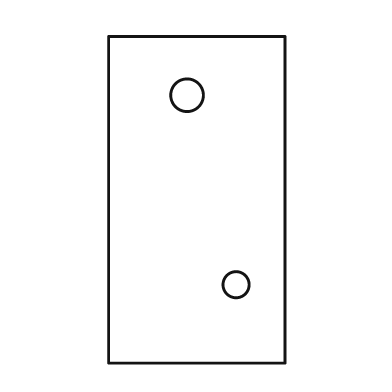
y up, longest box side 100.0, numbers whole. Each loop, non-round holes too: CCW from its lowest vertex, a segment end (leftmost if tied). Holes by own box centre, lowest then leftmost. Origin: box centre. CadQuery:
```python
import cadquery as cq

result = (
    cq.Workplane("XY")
    .moveTo(-27.0, -50.0)
    .lineTo(27.0, -50.0)
    .lineTo(27.0, 50.0)
    .lineTo(-27.0, 50.0)
    .close()
    .moveTo(12.0, -26.0)
    .circle(4.0)
    .moveTo(-3.0, 32.0)
    .circle(5.0)
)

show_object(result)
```